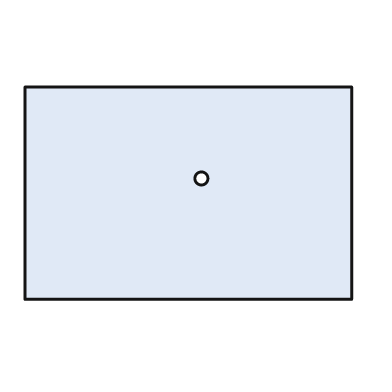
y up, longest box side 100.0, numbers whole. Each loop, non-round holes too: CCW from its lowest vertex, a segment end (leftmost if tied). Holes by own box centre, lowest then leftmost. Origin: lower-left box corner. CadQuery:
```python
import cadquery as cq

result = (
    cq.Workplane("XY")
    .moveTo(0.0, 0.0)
    .lineTo(100.0, 0.0)
    .lineTo(100.0, 65.0)
    .lineTo(0.0, 65.0)
    .close()
    .moveTo(54.0, 37.0)
    .circle(2.0)
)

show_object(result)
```